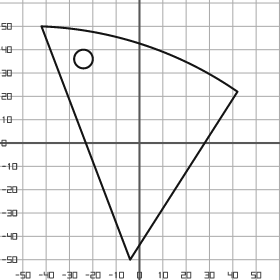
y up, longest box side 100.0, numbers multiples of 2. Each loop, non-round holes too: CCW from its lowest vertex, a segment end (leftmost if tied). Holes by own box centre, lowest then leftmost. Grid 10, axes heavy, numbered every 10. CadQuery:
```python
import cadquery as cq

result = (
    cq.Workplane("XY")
    .moveTo(-4.0, -50.0)
    .lineTo(42.0, 22.0)
    .threePointArc((2.0, 42.0), (-42.0, 50.0))
    .close()
    .moveTo(-24.0, 36.0)
    .circle(4.0)
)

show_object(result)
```